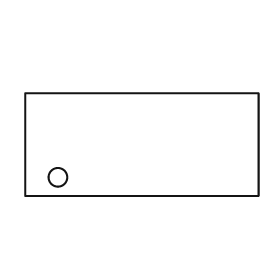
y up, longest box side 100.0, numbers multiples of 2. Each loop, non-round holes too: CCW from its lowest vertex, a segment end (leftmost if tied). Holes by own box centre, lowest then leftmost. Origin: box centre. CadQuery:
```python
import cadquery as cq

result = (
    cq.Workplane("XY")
    .moveTo(-50.0, -22.0)
    .lineTo(50.0, -22.0)
    .lineTo(50.0, 22.0)
    .lineTo(-50.0, 22.0)
    .close()
    .moveTo(-36.0, -14.0)
    .circle(4.0)
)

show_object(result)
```